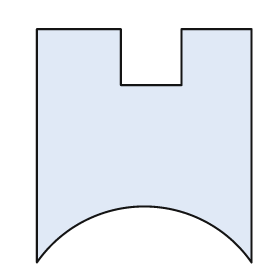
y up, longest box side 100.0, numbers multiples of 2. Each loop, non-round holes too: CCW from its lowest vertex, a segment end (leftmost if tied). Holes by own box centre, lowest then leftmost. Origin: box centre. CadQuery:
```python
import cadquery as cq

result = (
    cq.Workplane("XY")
    .moveTo(-46.0, -50.0)
    .threePointArc((0.0, -26.0), (46.0, -50.0))
    .lineTo(46.0, 50.0)
    .lineTo(16.0, 50.0)
    .lineTo(16.0, 26.0)
    .lineTo(-10.0, 26.0)
    .lineTo(-10.0, 50.0)
    .lineTo(-46.0, 50.0)
    .close()
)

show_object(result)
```